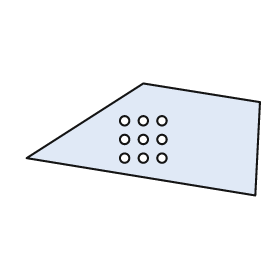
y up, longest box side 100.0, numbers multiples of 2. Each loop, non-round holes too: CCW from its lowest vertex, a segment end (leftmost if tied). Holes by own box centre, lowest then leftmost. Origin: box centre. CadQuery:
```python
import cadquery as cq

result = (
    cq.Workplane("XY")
    .moveTo(48.0, -24.0)
    .lineTo(50.0, 16.0)
    .lineTo(0.0, 24.0)
    .lineTo(-50.0, -8.0)
    .close()
    .moveTo(-8.0, -8.0)
    .circle(2.0)
    .moveTo(0.0, -8.0)
    .circle(2.0)
    .moveTo(8.0, -8.0)
    .circle(2.0)
    .moveTo(-8.0, 0.0)
    .circle(2.0)
    .moveTo(0.0, 0.0)
    .circle(2.0)
    .moveTo(8.0, 0.0)
    .circle(2.0)
    .moveTo(-8.0, 8.0)
    .circle(2.0)
    .moveTo(0.0, 8.0)
    .circle(2.0)
    .moveTo(8.0, 8.0)
    .circle(2.0)
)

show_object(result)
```